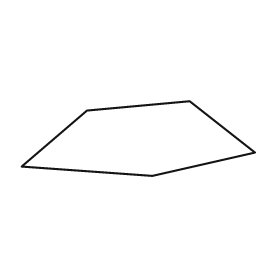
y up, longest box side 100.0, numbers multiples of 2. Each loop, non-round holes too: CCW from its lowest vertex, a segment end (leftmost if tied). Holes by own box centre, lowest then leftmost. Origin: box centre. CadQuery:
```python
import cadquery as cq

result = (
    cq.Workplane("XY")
    .moveTo(6.0, -16.0)
    .lineTo(50.0, -6.0)
    .lineTo(22.0, 16.0)
    .lineTo(-22.0, 12.0)
    .lineTo(-50.0, -12.0)
    .close()
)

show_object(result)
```